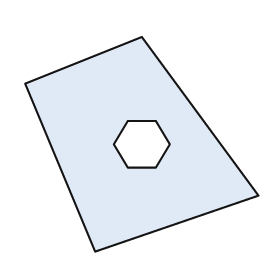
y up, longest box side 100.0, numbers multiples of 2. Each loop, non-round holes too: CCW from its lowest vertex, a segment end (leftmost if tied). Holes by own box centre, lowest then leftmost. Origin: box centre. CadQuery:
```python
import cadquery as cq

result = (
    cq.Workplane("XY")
    .moveTo(-20.0, -46.0)
    .lineTo(50.0, -22.0)
    .lineTo(0.0, 46.0)
    .lineTo(-50.0, 26.0)
    .close()
    .moveTo(-6.0, -10.0)
    .lineTo(6.0, -10.0)
    .lineTo(12.0, 0.0)
    .lineTo(6.0, 10.0)
    .lineTo(-6.0, 10.0)
    .lineTo(-12.0, 0.0)
    .close()
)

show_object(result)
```